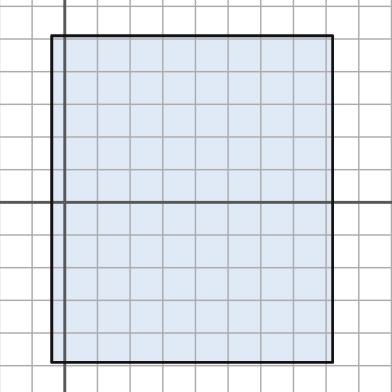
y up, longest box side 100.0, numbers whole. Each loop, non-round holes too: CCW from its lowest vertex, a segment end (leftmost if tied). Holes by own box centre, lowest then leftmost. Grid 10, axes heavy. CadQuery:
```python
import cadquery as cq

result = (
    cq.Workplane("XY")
    .moveTo(-4.0, -49.0)
    .lineTo(82.0, -49.0)
    .lineTo(82.0, 51.0)
    .lineTo(-4.0, 51.0)
    .close()
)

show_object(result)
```